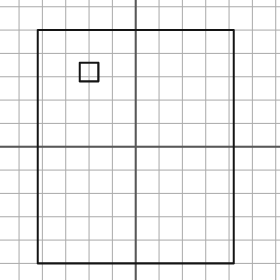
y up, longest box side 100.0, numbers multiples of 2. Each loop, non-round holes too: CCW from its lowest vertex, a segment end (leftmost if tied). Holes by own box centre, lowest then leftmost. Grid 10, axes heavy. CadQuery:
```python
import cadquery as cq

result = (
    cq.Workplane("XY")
    .moveTo(-42.0, -50.0)
    .lineTo(42.0, -50.0)
    .lineTo(42.0, 50.0)
    .lineTo(-42.0, 50.0)
    .close()
    .moveTo(-24.0, 28.0)
    .lineTo(-16.0, 28.0)
    .lineTo(-16.0, 36.0)
    .lineTo(-24.0, 36.0)
    .close()
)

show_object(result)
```